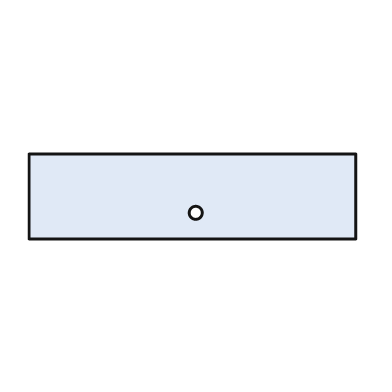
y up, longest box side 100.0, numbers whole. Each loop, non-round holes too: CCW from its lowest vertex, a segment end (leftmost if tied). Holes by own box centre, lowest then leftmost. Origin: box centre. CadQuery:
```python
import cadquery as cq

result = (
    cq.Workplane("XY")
    .moveTo(-50.0, -13.0)
    .lineTo(50.0, -13.0)
    .lineTo(50.0, 13.0)
    .lineTo(-50.0, 13.0)
    .close()
    .moveTo(1.0, -5.0)
    .circle(2.0)
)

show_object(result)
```